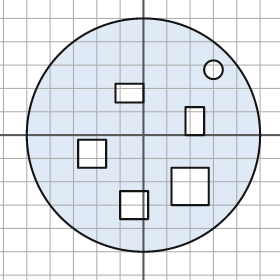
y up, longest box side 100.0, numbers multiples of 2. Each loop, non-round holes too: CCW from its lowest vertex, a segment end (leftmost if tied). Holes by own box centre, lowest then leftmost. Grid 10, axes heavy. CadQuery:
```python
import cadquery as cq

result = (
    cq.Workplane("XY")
    .moveTo(0.0, 0.0)
    .circle(50.0)
    .moveTo(-10.0, -36.0)
    .lineTo(2.0, -36.0)
    .lineTo(2.0, -24.0)
    .lineTo(-10.0, -24.0)
    .close()
    .moveTo(12.0, -30.0)
    .lineTo(28.0, -30.0)
    .lineTo(28.0, -14.0)
    .lineTo(12.0, -14.0)
    .close()
    .moveTo(-28.0, -14.0)
    .lineTo(-16.0, -14.0)
    .lineTo(-16.0, -2.0)
    .lineTo(-28.0, -2.0)
    .close()
    .moveTo(18.0, 0.0)
    .lineTo(26.0, 0.0)
    .lineTo(26.0, 12.0)
    .lineTo(18.0, 12.0)
    .close()
    .moveTo(-12.0, 14.0)
    .lineTo(0.0, 14.0)
    .lineTo(0.0, 22.0)
    .lineTo(-12.0, 22.0)
    .close()
    .moveTo(30.0, 28.0)
    .circle(4.0)
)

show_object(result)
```